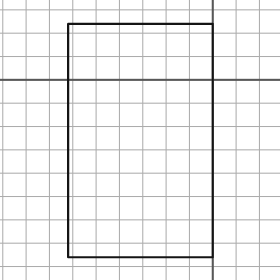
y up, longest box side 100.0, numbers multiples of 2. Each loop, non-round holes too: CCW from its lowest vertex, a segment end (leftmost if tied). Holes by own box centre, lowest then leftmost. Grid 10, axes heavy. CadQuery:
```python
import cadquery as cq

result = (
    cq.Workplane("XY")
    .moveTo(-62.0, -76.0)
    .lineTo(0.0, -76.0)
    .lineTo(0.0, 24.0)
    .lineTo(-62.0, 24.0)
    .close()
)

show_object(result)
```